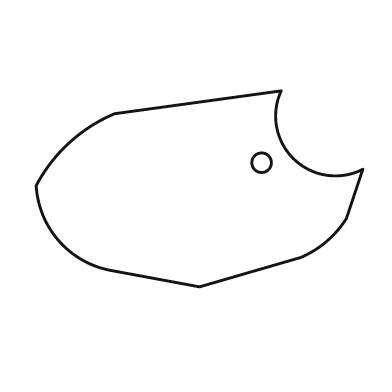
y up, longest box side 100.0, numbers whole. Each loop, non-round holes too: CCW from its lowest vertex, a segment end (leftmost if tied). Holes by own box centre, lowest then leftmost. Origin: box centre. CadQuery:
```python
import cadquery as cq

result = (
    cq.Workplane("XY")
    .moveTo(0.0, -30.0)
    .lineTo(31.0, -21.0)
    .threePointArc((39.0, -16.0), (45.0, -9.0))
    .lineTo(50.0, 6.0)
    .threePointArc((29.0, 9.0), (25.0, 30.0))
    .lineTo(-26.0, 23.0)
    .threePointArc((-40.0, 14.0), (-50.0, 1.0))
    .threePointArc((-43.0, -16.0), (-27.0, -25.0))
    .close()
    .moveTo(19.0, 8.0)
    .circle(3.0)
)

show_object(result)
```